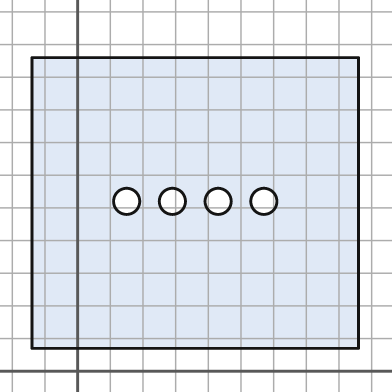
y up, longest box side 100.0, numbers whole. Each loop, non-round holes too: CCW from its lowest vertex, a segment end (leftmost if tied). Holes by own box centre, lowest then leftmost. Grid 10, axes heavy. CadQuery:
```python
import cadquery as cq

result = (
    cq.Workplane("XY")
    .moveTo(-14.0, 7.0)
    .lineTo(86.0, 7.0)
    .lineTo(86.0, 96.0)
    .lineTo(-14.0, 96.0)
    .close()
    .moveTo(15.0, 52.0)
    .circle(4.0)
    .moveTo(29.0, 52.0)
    .circle(4.0)
    .moveTo(43.0, 52.0)
    .circle(4.0)
    .moveTo(57.0, 52.0)
    .circle(4.0)
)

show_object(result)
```